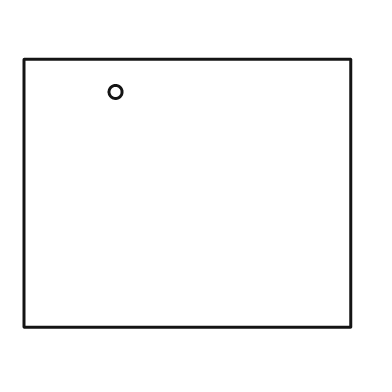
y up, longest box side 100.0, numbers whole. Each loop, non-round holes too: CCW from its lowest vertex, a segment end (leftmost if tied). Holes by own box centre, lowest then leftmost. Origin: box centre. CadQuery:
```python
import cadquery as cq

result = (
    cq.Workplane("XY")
    .moveTo(-50.0, -41.0)
    .lineTo(50.0, -41.0)
    .lineTo(50.0, 41.0)
    .lineTo(-50.0, 41.0)
    .close()
    .moveTo(-22.0, 31.0)
    .circle(2.0)
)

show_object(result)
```